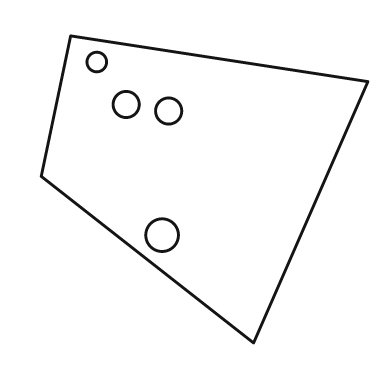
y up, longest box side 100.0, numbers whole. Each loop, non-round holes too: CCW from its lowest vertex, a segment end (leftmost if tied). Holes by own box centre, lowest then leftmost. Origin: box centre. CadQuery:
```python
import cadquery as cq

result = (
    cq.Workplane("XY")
    .moveTo(15.0, -47.0)
    .lineTo(50.0, 33.0)
    .lineTo(-41.0, 47.0)
    .lineTo(-50.0, 4.0)
    .close()
    .moveTo(-13.0, -14.0)
    .circle(5.0)
    .moveTo(-11.0, 24.0)
    .circle(4.0)
    .moveTo(-24.0, 26.0)
    .circle(4.0)
    .moveTo(-33.0, 39.0)
    .circle(3.0)
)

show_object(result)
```